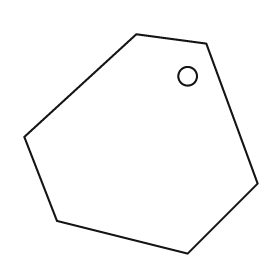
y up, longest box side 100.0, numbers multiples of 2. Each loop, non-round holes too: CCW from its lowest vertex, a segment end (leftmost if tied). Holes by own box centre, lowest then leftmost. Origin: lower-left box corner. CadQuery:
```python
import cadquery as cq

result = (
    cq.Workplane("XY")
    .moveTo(70.0, 0.0)
    .lineTo(100.0, 30.0)
    .lineTo(78.0, 90.0)
    .lineTo(48.0, 94.0)
    .lineTo(0.0, 50.0)
    .lineTo(14.0, 14.0)
    .close()
    .moveTo(70.0, 76.0)
    .circle(4.0)
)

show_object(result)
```